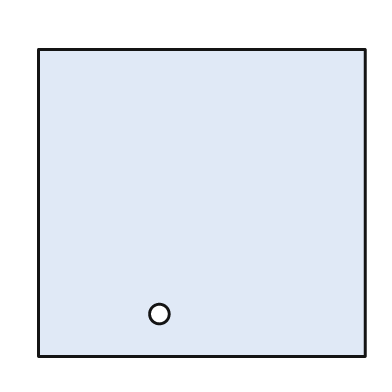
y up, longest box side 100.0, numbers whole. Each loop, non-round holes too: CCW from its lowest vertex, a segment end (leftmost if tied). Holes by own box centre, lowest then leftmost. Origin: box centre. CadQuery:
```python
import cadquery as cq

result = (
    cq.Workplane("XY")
    .moveTo(-50.0, -47.0)
    .lineTo(50.0, -47.0)
    .lineTo(50.0, 47.0)
    .lineTo(-50.0, 47.0)
    .close()
    .moveTo(-13.0, -34.0)
    .circle(3.0)
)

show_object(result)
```